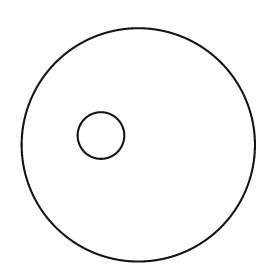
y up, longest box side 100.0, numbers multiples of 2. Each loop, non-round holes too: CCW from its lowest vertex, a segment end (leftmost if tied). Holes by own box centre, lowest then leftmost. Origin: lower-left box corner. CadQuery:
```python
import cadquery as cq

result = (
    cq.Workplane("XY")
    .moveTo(50.0, 50.0)
    .circle(50.0)
    .moveTo(34.0, 54.0)
    .circle(10.0)
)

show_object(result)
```